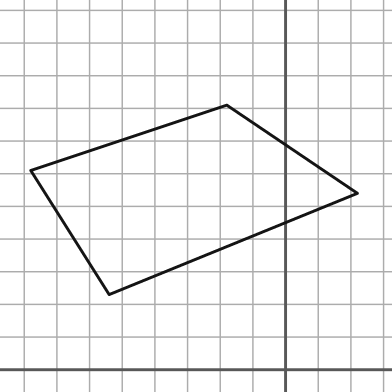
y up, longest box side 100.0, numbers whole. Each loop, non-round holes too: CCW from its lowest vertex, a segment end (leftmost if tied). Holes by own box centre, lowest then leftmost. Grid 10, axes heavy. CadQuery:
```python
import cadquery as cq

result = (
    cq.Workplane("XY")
    .moveTo(-54.0, 23.0)
    .lineTo(22.0, 54.0)
    .lineTo(-18.0, 81.0)
    .lineTo(-78.0, 61.0)
    .close()
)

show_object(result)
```